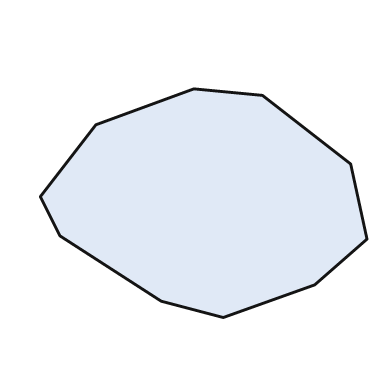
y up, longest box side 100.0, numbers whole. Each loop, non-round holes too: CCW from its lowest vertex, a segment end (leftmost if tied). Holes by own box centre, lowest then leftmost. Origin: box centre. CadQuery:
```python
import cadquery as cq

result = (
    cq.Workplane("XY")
    .moveTo(6.0, -35.0)
    .lineTo(34.0, -25.0)
    .lineTo(50.0, -11.0)
    .lineTo(45.0, 12.0)
    .lineTo(18.0, 33.0)
    .lineTo(-3.0, 35.0)
    .lineTo(-33.0, 24.0)
    .lineTo(-50.0, 2.0)
    .lineTo(-44.0, -10.0)
    .lineTo(-13.0, -30.0)
    .close()
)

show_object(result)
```